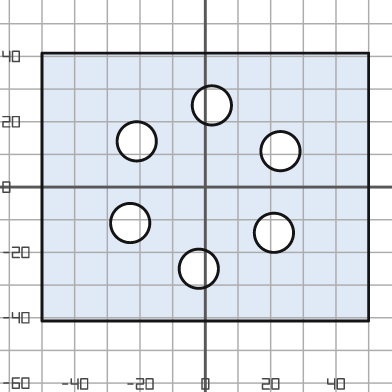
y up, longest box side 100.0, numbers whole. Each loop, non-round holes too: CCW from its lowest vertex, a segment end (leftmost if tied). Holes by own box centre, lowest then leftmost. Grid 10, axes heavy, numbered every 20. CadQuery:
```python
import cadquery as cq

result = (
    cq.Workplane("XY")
    .moveTo(-50.0, -41.0)
    .lineTo(50.0, -41.0)
    .lineTo(50.0, 41.0)
    .lineTo(-50.0, 41.0)
    .close()
    .moveTo(-2.0, -25.0)
    .circle(6.0)
    .moveTo(21.0, -14.0)
    .circle(6.0)
    .moveTo(-23.0, -11.0)
    .circle(6.0)
    .moveTo(23.0, 11.0)
    .circle(6.0)
    .moveTo(-21.0, 14.0)
    .circle(6.0)
    .moveTo(2.0, 25.0)
    .circle(6.0)
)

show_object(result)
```